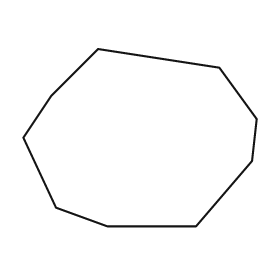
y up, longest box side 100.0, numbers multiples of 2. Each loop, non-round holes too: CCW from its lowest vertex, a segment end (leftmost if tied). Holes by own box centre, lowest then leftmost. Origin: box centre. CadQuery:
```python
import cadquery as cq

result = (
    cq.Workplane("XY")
    .moveTo(-14.0, -38.0)
    .lineTo(24.0, -38.0)
    .lineTo(48.0, -10.0)
    .lineTo(50.0, 8.0)
    .lineTo(34.0, 30.0)
    .lineTo(-18.0, 38.0)
    .lineTo(-38.0, 18.0)
    .lineTo(-50.0, 0.0)
    .lineTo(-36.0, -30.0)
    .close()
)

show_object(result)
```